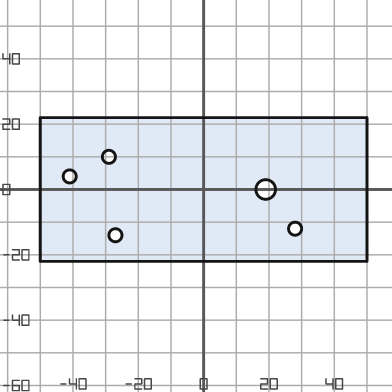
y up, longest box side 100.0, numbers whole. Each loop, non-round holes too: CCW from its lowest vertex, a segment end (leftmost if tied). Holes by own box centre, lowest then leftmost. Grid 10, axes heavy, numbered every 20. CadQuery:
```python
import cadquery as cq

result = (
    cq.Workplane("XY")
    .moveTo(-50.0, -22.0)
    .lineTo(50.0, -22.0)
    .lineTo(50.0, 22.0)
    .lineTo(-50.0, 22.0)
    .close()
    .moveTo(-27.0, -14.0)
    .circle(2.0)
    .moveTo(28.0, -12.0)
    .circle(2.0)
    .moveTo(19.0, 0.0)
    .circle(3.0)
    .moveTo(-41.0, 4.0)
    .circle(2.0)
    .moveTo(-29.0, 10.0)
    .circle(2.0)
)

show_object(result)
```